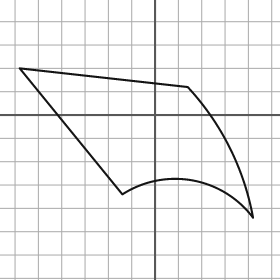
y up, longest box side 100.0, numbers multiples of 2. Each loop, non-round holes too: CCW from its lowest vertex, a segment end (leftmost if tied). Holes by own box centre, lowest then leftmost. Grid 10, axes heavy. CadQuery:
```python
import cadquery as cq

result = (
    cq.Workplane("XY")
    .moveTo(42.0, -44.0)
    .threePointArc((32.0, -14.0), (14.0, 12.0))
    .lineTo(-58.0, 20.0)
    .lineTo(-14.0, -34.0)
    .threePointArc((16.0, -28.0), (42.0, -44.0))
    .close()
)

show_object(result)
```